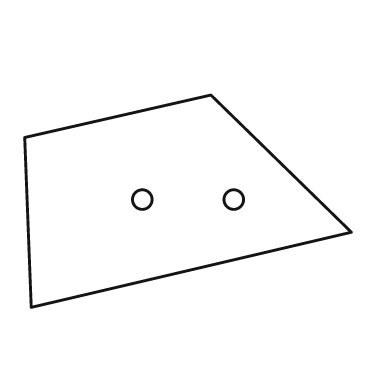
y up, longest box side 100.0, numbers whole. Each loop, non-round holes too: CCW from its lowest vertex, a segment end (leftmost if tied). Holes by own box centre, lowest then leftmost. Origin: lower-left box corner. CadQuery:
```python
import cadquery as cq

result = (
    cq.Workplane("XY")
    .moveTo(2.0, 0.0)
    .lineTo(100.0, 23.0)
    .lineTo(57.0, 65.0)
    .lineTo(0.0, 52.0)
    .close()
    .moveTo(36.0, 33.0)
    .circle(3.0)
    .moveTo(64.0, 33.0)
    .circle(3.0)
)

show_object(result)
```